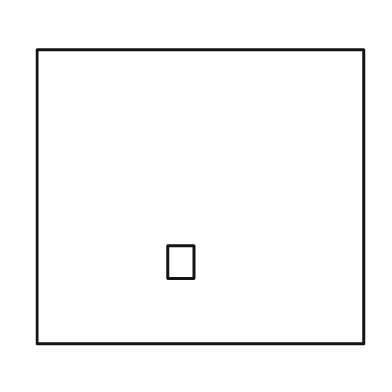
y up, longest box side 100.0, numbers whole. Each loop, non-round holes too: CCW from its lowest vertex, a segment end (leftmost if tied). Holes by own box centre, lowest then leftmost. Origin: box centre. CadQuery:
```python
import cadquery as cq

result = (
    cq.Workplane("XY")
    .moveTo(-50.0, -45.0)
    .lineTo(50.0, -45.0)
    .lineTo(50.0, 45.0)
    .lineTo(-50.0, 45.0)
    .close()
    .moveTo(-10.0, -25.0)
    .lineTo(-2.0, -25.0)
    .lineTo(-2.0, -15.0)
    .lineTo(-10.0, -15.0)
    .close()
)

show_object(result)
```